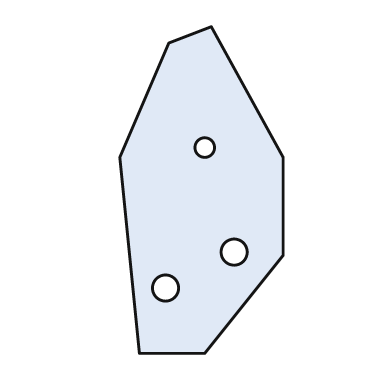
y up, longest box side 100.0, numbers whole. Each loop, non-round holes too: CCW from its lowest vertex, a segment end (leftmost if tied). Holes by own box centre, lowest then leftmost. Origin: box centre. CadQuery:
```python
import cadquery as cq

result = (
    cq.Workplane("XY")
    .moveTo(-19.0, -50.0)
    .lineTo(1.0, -50.0)
    .lineTo(25.0, -20.0)
    .lineTo(25.0, 10.0)
    .lineTo(3.0, 50.0)
    .lineTo(-10.0, 45.0)
    .lineTo(-25.0, 10.0)
    .close()
    .moveTo(-11.0, -30.0)
    .circle(4.0)
    .moveTo(10.0, -19.0)
    .circle(4.0)
    .moveTo(1.0, 13.0)
    .circle(3.0)
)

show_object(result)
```